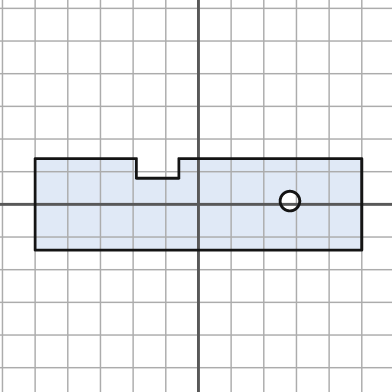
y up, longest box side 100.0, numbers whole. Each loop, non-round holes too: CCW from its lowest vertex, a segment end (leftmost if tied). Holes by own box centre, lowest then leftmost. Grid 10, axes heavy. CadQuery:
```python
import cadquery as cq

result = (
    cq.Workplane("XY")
    .moveTo(-50.0, -14.0)
    .lineTo(50.0, -14.0)
    .lineTo(50.0, 14.0)
    .lineTo(-6.0, 14.0)
    .lineTo(-6.0, 8.0)
    .lineTo(-19.0, 8.0)
    .lineTo(-19.0, 14.0)
    .lineTo(-50.0, 14.0)
    .close()
    .moveTo(28.0, 1.0)
    .circle(3.0)
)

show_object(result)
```